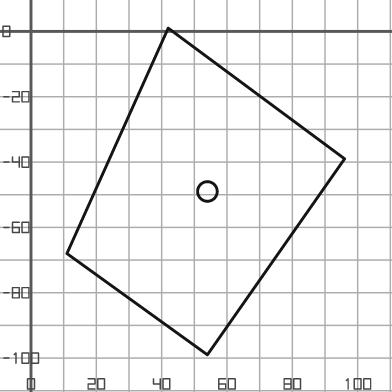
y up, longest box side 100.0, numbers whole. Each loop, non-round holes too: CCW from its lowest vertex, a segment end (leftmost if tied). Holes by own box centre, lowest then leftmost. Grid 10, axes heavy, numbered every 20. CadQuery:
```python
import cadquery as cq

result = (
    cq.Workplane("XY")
    .moveTo(54.0, -99.0)
    .lineTo(96.0, -39.0)
    .lineTo(42.0, 1.0)
    .lineTo(11.0, -68.0)
    .close()
    .moveTo(54.0, -49.0)
    .circle(3.0)
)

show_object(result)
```